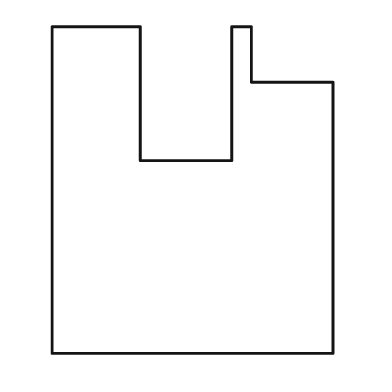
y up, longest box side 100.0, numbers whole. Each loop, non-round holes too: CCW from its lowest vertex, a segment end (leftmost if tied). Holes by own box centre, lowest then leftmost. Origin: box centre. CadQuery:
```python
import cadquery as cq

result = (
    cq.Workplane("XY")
    .moveTo(-43.0, -50.0)
    .lineTo(43.0, -50.0)
    .lineTo(43.0, 33.0)
    .lineTo(18.0, 33.0)
    .lineTo(18.0, 50.0)
    .lineTo(12.0, 50.0)
    .lineTo(12.0, 9.0)
    .lineTo(-16.0, 9.0)
    .lineTo(-16.0, 50.0)
    .lineTo(-43.0, 50.0)
    .close()
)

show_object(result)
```